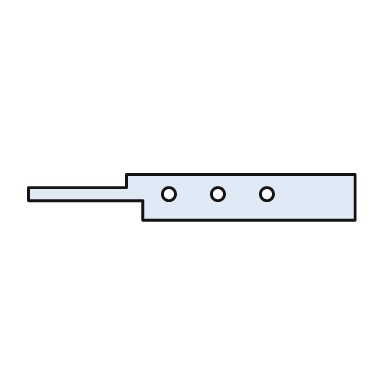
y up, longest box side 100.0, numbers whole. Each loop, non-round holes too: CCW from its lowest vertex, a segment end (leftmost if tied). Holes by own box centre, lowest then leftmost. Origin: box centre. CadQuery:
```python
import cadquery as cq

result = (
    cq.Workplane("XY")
    .moveTo(-15.0, -7.0)
    .lineTo(50.0, -7.0)
    .lineTo(50.0, 7.0)
    .lineTo(-20.0, 7.0)
    .lineTo(-20.0, 3.0)
    .lineTo(-50.0, 3.0)
    .lineTo(-50.0, -1.0)
    .lineTo(-15.0, -1.0)
    .close()
    .moveTo(-7.0, 1.0)
    .circle(2.0)
    .moveTo(8.0, 1.0)
    .circle(2.0)
    .moveTo(23.0, 1.0)
    .circle(2.0)
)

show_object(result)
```